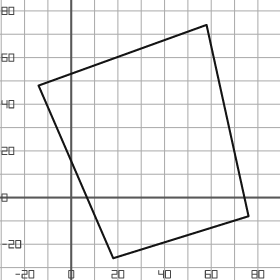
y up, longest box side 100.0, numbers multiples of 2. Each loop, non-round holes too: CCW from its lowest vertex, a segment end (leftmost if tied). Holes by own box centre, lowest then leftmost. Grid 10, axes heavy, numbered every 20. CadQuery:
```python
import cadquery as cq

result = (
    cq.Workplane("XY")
    .moveTo(18.0, -26.0)
    .lineTo(76.0, -8.0)
    .lineTo(58.0, 74.0)
    .lineTo(-14.0, 48.0)
    .close()
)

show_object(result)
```